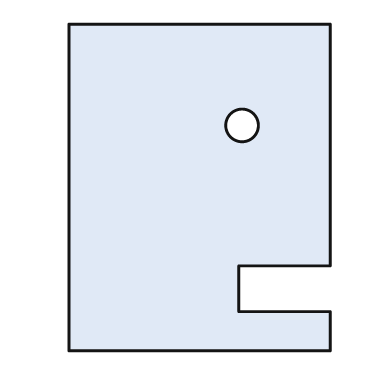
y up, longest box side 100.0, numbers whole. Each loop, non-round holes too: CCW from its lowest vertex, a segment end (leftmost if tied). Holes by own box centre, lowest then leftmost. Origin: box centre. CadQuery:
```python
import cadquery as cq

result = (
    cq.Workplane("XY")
    .moveTo(-40.0, -50.0)
    .lineTo(40.0, -50.0)
    .lineTo(40.0, -38.0)
    .lineTo(12.0, -38.0)
    .lineTo(12.0, -24.0)
    .lineTo(40.0, -24.0)
    .lineTo(40.0, 50.0)
    .lineTo(-40.0, 50.0)
    .close()
    .moveTo(13.0, 19.0)
    .circle(5.0)
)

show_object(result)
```